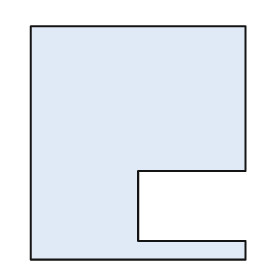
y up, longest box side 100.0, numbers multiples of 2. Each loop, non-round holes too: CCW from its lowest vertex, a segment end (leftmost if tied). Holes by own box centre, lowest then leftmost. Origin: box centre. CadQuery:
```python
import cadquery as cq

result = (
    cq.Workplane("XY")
    .moveTo(-46.0, -50.0)
    .lineTo(46.0, -50.0)
    .lineTo(46.0, -42.0)
    .lineTo(0.0, -42.0)
    .lineTo(0.0, -12.0)
    .lineTo(46.0, -12.0)
    .lineTo(46.0, 50.0)
    .lineTo(-46.0, 50.0)
    .close()
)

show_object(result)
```